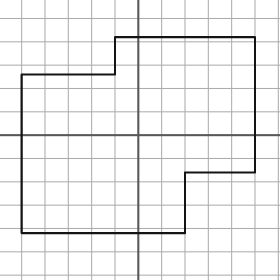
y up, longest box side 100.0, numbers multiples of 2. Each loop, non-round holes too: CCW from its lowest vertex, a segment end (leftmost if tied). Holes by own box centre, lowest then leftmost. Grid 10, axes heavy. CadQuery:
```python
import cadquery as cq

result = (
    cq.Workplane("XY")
    .moveTo(-50.0, -42.0)
    .lineTo(20.0, -42.0)
    .lineTo(20.0, -16.0)
    .lineTo(50.0, -16.0)
    .lineTo(50.0, 42.0)
    .lineTo(-10.0, 42.0)
    .lineTo(-10.0, 26.0)
    .lineTo(-50.0, 26.0)
    .close()
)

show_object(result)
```